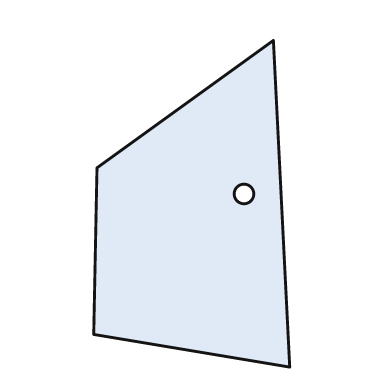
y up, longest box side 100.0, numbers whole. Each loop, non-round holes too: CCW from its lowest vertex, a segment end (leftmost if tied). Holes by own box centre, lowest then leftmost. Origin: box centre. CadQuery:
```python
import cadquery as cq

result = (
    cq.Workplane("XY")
    .moveTo(30.0, -50.0)
    .lineTo(25.0, 50.0)
    .lineTo(-29.0, 11.0)
    .lineTo(-30.0, -40.0)
    .close()
    .moveTo(16.0, 3.0)
    .circle(3.0)
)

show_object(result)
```